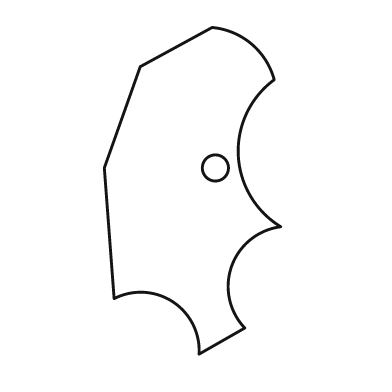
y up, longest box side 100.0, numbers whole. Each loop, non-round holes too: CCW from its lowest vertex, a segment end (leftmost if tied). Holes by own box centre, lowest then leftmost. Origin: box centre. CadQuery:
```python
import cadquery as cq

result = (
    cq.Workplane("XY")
    .moveTo(2.0, -50.0)
    .lineTo(16.0, -42.0)
    .threePointArc((12.0, -23.0), (27.0, -11.0))
    .threePointArc((14.0, 11.0), (25.0, 34.0))
    .threePointArc((18.0, 45.0), (6.0, 50.0))
    .lineTo(-16.0, 38.0)
    .lineTo(-27.0, 7.0)
    .lineTo(-24.0, -33.0)
    .threePointArc((-6.0, -34.0), (2.0, -50.0))
    .close()
    .moveTo(7.0, 7.0)
    .circle(4.0)
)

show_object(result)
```